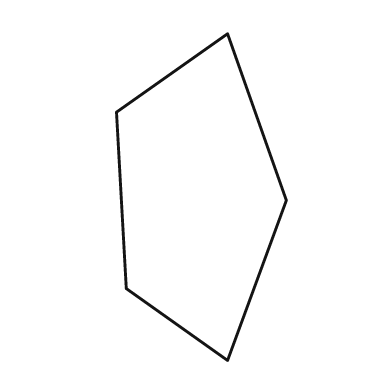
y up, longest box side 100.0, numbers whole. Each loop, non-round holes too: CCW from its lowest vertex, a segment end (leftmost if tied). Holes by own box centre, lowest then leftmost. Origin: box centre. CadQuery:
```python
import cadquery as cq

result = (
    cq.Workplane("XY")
    .moveTo(8.0, -50.0)
    .lineTo(26.0, -1.0)
    .lineTo(8.0, 50.0)
    .lineTo(-26.0, 26.0)
    .lineTo(-23.0, -28.0)
    .close()
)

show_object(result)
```